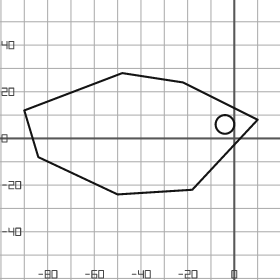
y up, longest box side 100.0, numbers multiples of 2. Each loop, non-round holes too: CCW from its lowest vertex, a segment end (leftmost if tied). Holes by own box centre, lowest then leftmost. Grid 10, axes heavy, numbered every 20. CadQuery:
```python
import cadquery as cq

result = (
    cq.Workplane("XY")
    .moveTo(-50.0, -24.0)
    .lineTo(-18.0, -22.0)
    .lineTo(10.0, 8.0)
    .lineTo(-22.0, 24.0)
    .lineTo(-48.0, 28.0)
    .lineTo(-90.0, 12.0)
    .lineTo(-84.0, -8.0)
    .close()
    .moveTo(-4.0, 6.0)
    .circle(4.0)
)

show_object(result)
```